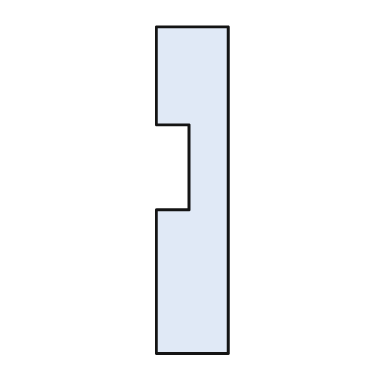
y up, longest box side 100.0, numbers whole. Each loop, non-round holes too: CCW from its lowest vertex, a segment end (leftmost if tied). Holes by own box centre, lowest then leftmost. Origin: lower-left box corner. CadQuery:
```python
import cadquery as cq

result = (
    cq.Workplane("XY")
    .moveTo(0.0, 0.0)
    .lineTo(22.0, 0.0)
    .lineTo(22.0, 100.0)
    .lineTo(0.0, 100.0)
    .lineTo(0.0, 70.0)
    .lineTo(10.0, 70.0)
    .lineTo(10.0, 44.0)
    .lineTo(0.0, 44.0)
    .close()
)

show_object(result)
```